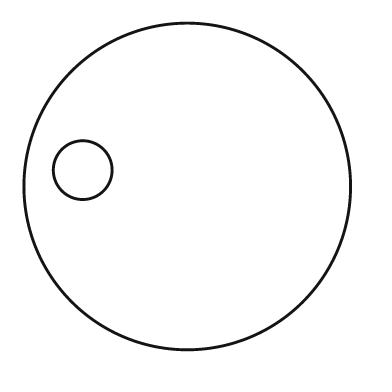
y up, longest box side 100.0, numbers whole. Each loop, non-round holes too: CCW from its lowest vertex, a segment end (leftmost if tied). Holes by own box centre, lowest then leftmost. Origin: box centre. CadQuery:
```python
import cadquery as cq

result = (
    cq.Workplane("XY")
    .moveTo(0.0, 0.0)
    .circle(50.0)
    .moveTo(-32.0, 5.0)
    .circle(9.0)
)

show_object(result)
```